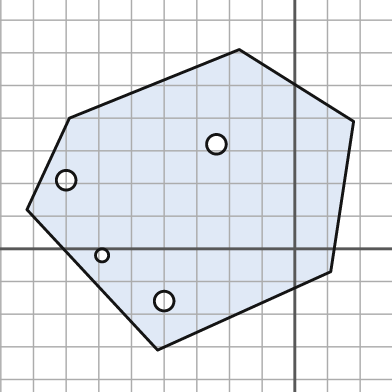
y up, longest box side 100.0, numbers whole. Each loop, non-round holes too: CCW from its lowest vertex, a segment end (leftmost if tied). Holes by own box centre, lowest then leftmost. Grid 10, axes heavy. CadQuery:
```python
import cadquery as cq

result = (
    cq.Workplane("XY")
    .moveTo(-42.0, -31.0)
    .lineTo(11.0, -7.0)
    .lineTo(18.0, 39.0)
    .lineTo(-17.0, 61.0)
    .lineTo(-69.0, 40.0)
    .lineTo(-82.0, 12.0)
    .close()
    .moveTo(-40.0, -16.0)
    .circle(3.0)
    .moveTo(-59.0, -2.0)
    .circle(2.0)
    .moveTo(-70.0, 21.0)
    .circle(3.0)
    .moveTo(-24.0, 32.0)
    .circle(3.0)
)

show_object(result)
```